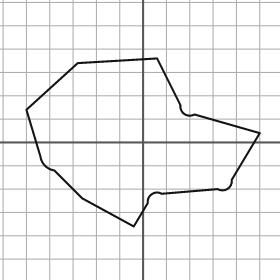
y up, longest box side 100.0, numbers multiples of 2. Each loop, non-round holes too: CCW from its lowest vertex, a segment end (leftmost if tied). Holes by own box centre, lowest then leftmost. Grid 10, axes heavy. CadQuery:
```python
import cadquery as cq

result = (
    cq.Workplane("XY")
    .moveTo(-4.0, -36.0)
    .lineTo(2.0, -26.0)
    .threePointArc((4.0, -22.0), (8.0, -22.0))
    .lineTo(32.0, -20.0)
    .threePointArc((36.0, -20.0), (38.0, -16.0))
    .lineTo(50.0, 4.0)
    .lineTo(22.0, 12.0)
    .threePointArc((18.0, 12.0), (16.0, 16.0))
    .lineTo(6.0, 36.0)
    .lineTo(-28.0, 34.0)
    .lineTo(-50.0, 14.0)
    .lineTo(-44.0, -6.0)
    .threePointArc((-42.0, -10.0), (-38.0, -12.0))
    .lineTo(-26.0, -24.0)
    .close()
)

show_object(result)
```